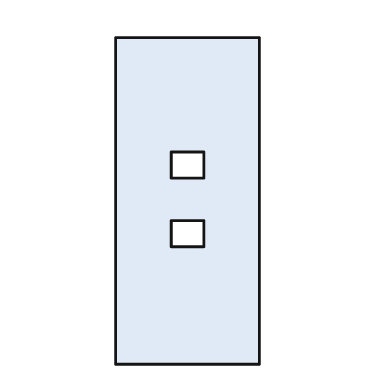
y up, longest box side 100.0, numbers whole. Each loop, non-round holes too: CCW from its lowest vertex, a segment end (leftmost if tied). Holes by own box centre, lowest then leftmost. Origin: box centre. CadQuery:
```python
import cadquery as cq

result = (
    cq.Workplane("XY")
    .moveTo(-22.0, -50.0)
    .lineTo(22.0, -50.0)
    .lineTo(22.0, 50.0)
    .lineTo(-22.0, 50.0)
    .close()
    .moveTo(-5.0, -14.0)
    .lineTo(5.0, -14.0)
    .lineTo(5.0, -6.0)
    .lineTo(-5.0, -6.0)
    .close()
    .moveTo(-5.0, 7.0)
    .lineTo(5.0, 7.0)
    .lineTo(5.0, 15.0)
    .lineTo(-5.0, 15.0)
    .close()
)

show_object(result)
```